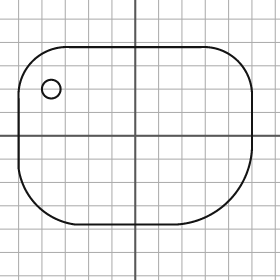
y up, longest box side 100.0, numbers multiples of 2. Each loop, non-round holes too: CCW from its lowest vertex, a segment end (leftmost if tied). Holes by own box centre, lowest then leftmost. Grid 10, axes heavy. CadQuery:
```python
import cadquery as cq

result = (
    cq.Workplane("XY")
    .moveTo(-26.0, -38.0)
    .lineTo(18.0, -38.0)
    .threePointArc((40.0, -28.0), (50.0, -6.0))
    .lineTo(50.0, 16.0)
    .threePointArc((44.0, 32.0), (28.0, 38.0))
    .lineTo(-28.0, 38.0)
    .threePointArc((-44.0, 32.0), (-50.0, 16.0))
    .lineTo(-50.0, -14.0)
    .threePointArc((-42.0, -30.0), (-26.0, -38.0))
    .close()
    .moveTo(-36.0, 20.0)
    .circle(4.0)
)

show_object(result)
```